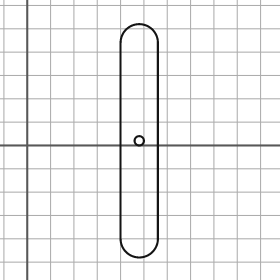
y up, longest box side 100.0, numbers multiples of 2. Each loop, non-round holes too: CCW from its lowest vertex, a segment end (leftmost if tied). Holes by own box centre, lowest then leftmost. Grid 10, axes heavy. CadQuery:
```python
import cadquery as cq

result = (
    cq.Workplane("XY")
    .moveTo(40.0, -40.0)
    .threePointArc((48.0, -48.0), (56.0, -40.0))
    .lineTo(56.0, 44.0)
    .threePointArc((48.0, 52.0), (40.0, 44.0))
    .close()
    .moveTo(48.0, 2.0)
    .circle(2.0)
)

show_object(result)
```